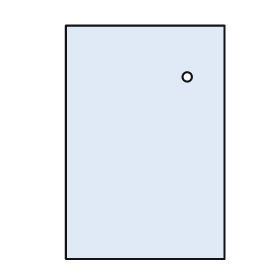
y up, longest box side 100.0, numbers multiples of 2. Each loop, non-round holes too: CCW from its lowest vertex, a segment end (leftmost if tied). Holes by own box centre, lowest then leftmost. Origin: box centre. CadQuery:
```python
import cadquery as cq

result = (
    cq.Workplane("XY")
    .moveTo(-34.0, -50.0)
    .lineTo(34.0, -50.0)
    .lineTo(34.0, 50.0)
    .lineTo(-34.0, 50.0)
    .close()
    .moveTo(18.0, 28.0)
    .circle(2.0)
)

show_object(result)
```